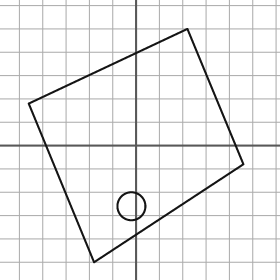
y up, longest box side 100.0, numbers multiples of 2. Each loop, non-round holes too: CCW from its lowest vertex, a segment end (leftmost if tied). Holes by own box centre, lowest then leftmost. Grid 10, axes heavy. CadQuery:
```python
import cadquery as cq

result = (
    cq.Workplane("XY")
    .moveTo(-18.0, -50.0)
    .lineTo(46.0, -8.0)
    .lineTo(22.0, 50.0)
    .lineTo(-46.0, 18.0)
    .close()
    .moveTo(-2.0, -26.0)
    .circle(6.0)
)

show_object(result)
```